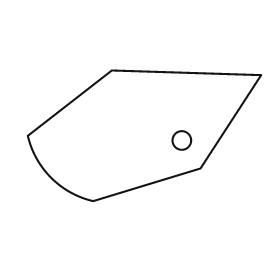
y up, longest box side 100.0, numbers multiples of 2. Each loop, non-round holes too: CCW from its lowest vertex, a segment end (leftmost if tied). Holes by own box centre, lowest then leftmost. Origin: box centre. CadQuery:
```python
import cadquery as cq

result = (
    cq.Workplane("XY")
    .moveTo(-22.0, -28.0)
    .lineTo(24.0, -14.0)
    .lineTo(50.0, 26.0)
    .lineTo(-14.0, 28.0)
    .lineTo(-50.0, 0.0)
    .threePointArc((-40.0, -18.0), (-22.0, -28.0))
    .close()
    .moveTo(16.0, -2.0)
    .circle(4.0)
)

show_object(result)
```